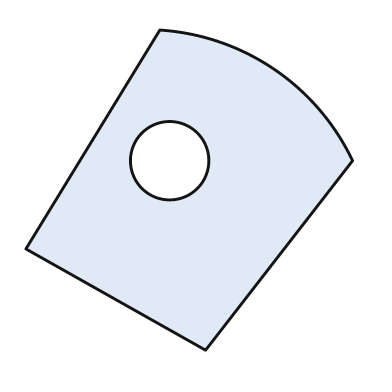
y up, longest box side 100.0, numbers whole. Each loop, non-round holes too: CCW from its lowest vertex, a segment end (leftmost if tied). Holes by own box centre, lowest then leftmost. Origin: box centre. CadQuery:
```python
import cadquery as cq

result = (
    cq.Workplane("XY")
    .moveTo(5.0, -49.0)
    .lineTo(50.0, 9.0)
    .threePointArc((26.0, 37.0), (-9.0, 49.0))
    .lineTo(-50.0, -18.0)
    .close()
    .moveTo(-6.0, 9.0)
    .circle(12.0)
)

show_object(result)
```